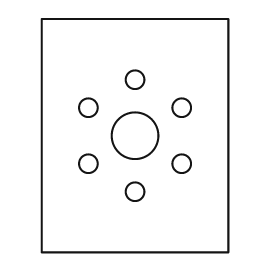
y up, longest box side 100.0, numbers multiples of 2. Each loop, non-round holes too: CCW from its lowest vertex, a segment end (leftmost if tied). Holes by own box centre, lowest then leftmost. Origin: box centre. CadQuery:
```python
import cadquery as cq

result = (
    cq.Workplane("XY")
    .moveTo(-40.0, -50.0)
    .lineTo(40.0, -50.0)
    .lineTo(40.0, 50.0)
    .lineTo(-40.0, 50.0)
    .close()
    .moveTo(0.0, -24.0)
    .circle(4.0)
    .moveTo(-20.0, -12.0)
    .circle(4.0)
    .moveTo(20.0, -12.0)
    .circle(4.0)
    .moveTo(0.0, 0.0)
    .circle(10.0)
    .moveTo(-20.0, 12.0)
    .circle(4.0)
    .moveTo(20.0, 12.0)
    .circle(4.0)
    .moveTo(0.0, 24.0)
    .circle(4.0)
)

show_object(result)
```